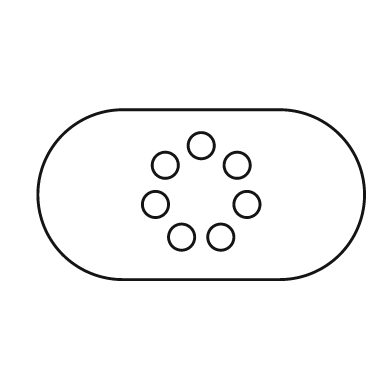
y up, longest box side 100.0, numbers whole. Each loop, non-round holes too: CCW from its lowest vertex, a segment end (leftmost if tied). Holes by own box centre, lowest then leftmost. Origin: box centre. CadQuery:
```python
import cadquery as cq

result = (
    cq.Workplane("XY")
    .moveTo(-24.0, -26.0)
    .lineTo(24.0, -26.0)
    .threePointArc((50.0, 0.0), (24.0, 26.0))
    .lineTo(-24.0, 26.0)
    .threePointArc((-50.0, 0.0), (-24.0, -26.0))
    .close()
    .moveTo(-6.0, -13.0)
    .circle(4.0)
    .moveTo(6.0, -13.0)
    .circle(4.0)
    .moveTo(-14.0, -3.0)
    .circle(4.0)
    .moveTo(14.0, -3.0)
    .circle(4.0)
    .moveTo(-11.0, 9.0)
    .circle(4.0)
    .moveTo(11.0, 9.0)
    .circle(4.0)
    .moveTo(0.0, 15.0)
    .circle(4.0)
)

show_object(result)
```